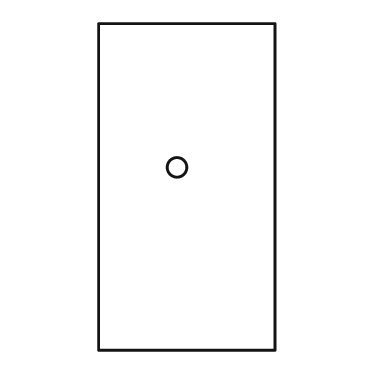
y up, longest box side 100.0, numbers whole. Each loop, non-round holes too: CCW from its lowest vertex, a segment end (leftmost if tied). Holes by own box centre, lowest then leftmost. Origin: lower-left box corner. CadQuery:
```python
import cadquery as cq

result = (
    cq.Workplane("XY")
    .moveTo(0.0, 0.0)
    .lineTo(54.0, 0.0)
    .lineTo(54.0, 100.0)
    .lineTo(0.0, 100.0)
    .close()
    .moveTo(24.0, 56.0)
    .circle(3.0)
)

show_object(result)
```